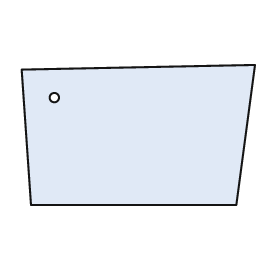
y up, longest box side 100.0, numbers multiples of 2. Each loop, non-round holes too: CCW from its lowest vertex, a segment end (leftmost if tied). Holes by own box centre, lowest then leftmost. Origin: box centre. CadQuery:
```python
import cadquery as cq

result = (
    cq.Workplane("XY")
    .moveTo(-46.0, -30.0)
    .lineTo(42.0, -30.0)
    .lineTo(50.0, 30.0)
    .lineTo(-50.0, 28.0)
    .close()
    .moveTo(-36.0, 16.0)
    .circle(2.0)
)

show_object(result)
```